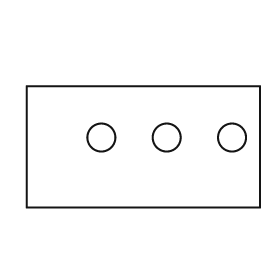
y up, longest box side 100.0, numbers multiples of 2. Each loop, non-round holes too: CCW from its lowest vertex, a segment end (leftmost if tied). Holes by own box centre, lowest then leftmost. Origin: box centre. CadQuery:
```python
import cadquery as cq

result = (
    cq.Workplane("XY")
    .moveTo(-50.0, -26.0)
    .lineTo(50.0, -26.0)
    .lineTo(50.0, 26.0)
    .lineTo(-50.0, 26.0)
    .close()
    .moveTo(-18.0, 4.0)
    .circle(6.0)
    .moveTo(10.0, 4.0)
    .circle(6.0)
    .moveTo(38.0, 4.0)
    .circle(6.0)
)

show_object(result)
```